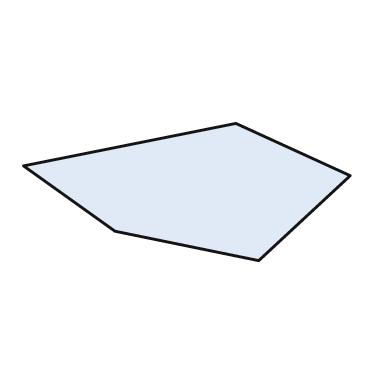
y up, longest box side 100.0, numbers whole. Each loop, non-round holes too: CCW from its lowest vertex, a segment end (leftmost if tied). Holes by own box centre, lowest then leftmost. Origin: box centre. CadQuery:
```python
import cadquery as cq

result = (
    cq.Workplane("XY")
    .moveTo(22.0, -21.0)
    .lineTo(50.0, 5.0)
    .lineTo(15.0, 21.0)
    .lineTo(-50.0, 8.0)
    .lineTo(-22.0, -12.0)
    .close()
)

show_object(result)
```